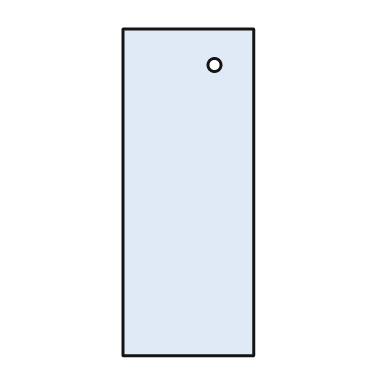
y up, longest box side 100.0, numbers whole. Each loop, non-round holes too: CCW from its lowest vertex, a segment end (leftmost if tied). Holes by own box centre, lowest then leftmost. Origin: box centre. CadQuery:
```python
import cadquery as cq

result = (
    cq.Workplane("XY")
    .moveTo(-20.0, -50.0)
    .lineTo(20.0, -50.0)
    .lineTo(20.0, 50.0)
    .lineTo(-20.0, 50.0)
    .close()
    .moveTo(8.0, 39.0)
    .circle(2.0)
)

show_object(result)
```